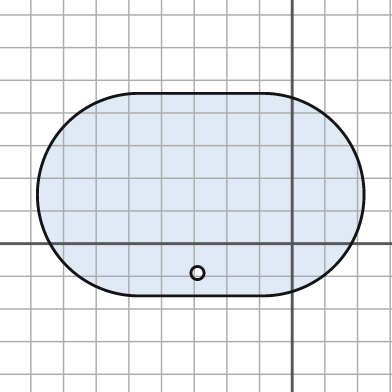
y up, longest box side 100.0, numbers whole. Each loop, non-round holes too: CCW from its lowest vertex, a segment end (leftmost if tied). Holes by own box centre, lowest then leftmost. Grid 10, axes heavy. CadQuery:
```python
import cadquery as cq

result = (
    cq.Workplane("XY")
    .moveTo(-47.0, -16.0)
    .lineTo(-9.0, -16.0)
    .threePointArc((22.0, 15.0), (-9.0, 46.0))
    .lineTo(-47.0, 46.0)
    .threePointArc((-78.0, 15.0), (-47.0, -16.0))
    .close()
    .moveTo(-29.0, -9.0)
    .circle(2.0)
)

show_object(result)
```